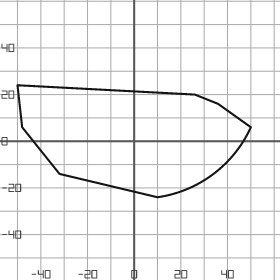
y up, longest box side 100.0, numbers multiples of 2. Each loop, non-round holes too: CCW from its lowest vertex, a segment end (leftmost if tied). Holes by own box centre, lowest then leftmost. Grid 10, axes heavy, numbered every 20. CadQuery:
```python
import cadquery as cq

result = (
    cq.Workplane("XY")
    .moveTo(10.0, -24.0)
    .threePointArc((34.0, -14.0), (50.0, 6.0))
    .lineTo(36.0, 16.0)
    .lineTo(26.0, 20.0)
    .lineTo(-50.0, 24.0)
    .lineTo(-48.0, 6.0)
    .lineTo(-32.0, -14.0)
    .close()
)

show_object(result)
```